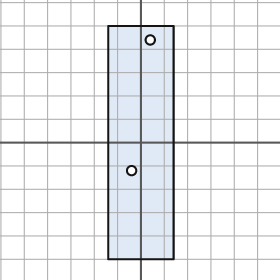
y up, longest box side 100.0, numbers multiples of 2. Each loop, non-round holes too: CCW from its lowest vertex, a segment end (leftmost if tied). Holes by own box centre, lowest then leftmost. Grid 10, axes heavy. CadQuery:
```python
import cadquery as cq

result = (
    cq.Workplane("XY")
    .moveTo(-14.0, -50.0)
    .lineTo(14.0, -50.0)
    .lineTo(14.0, 50.0)
    .lineTo(-14.0, 50.0)
    .close()
    .moveTo(-4.0, -12.0)
    .circle(2.0)
    .moveTo(4.0, 44.0)
    .circle(2.0)
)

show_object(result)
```